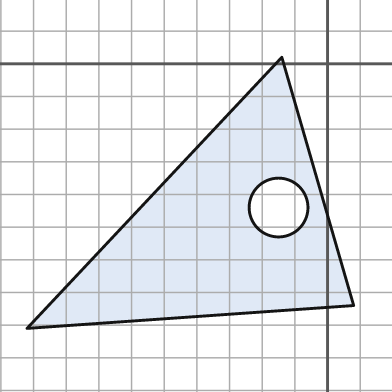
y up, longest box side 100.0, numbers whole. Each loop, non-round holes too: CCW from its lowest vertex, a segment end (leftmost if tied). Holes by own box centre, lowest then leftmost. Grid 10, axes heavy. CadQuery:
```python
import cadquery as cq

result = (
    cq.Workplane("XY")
    .moveTo(-92.0, -81.0)
    .lineTo(8.0, -74.0)
    .lineTo(-14.0, 2.0)
    .close()
    .moveTo(-15.0, -44.0)
    .circle(9.0)
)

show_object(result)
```